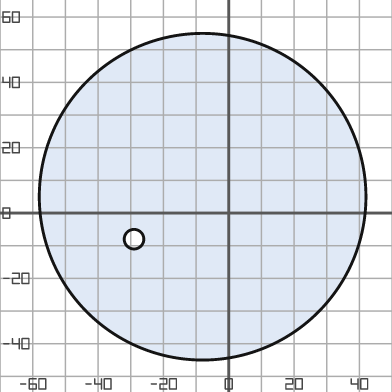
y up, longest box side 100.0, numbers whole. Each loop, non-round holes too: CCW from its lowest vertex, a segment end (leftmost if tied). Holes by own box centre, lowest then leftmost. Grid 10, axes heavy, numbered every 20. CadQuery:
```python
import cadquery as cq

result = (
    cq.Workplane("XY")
    .moveTo(-8.0, 5.0)
    .circle(50.0)
    .moveTo(-29.0, -8.0)
    .circle(3.0)
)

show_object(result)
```